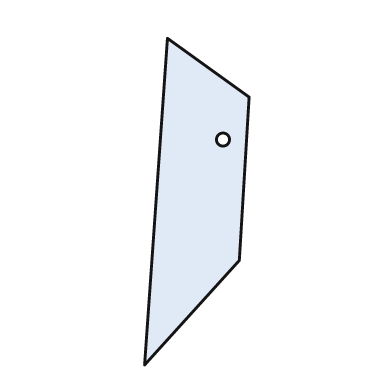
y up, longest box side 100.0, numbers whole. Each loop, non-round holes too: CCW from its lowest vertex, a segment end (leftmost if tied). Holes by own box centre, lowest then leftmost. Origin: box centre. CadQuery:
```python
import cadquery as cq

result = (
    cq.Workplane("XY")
    .moveTo(-16.0, -50.0)
    .lineTo(13.0, -18.0)
    .lineTo(16.0, 32.0)
    .lineTo(-9.0, 50.0)
    .close()
    .moveTo(8.0, 19.0)
    .circle(2.0)
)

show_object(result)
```